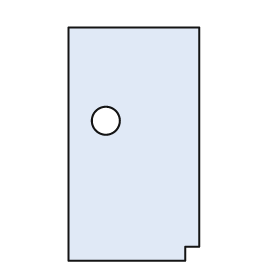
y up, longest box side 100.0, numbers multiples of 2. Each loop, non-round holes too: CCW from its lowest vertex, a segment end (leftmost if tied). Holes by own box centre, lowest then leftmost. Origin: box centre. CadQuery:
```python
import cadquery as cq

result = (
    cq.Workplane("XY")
    .moveTo(-28.0, -50.0)
    .lineTo(22.0, -50.0)
    .lineTo(22.0, -44.0)
    .lineTo(28.0, -44.0)
    .lineTo(28.0, 50.0)
    .lineTo(-28.0, 50.0)
    .close()
    .moveTo(-12.0, 10.0)
    .circle(6.0)
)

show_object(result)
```